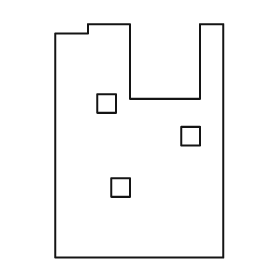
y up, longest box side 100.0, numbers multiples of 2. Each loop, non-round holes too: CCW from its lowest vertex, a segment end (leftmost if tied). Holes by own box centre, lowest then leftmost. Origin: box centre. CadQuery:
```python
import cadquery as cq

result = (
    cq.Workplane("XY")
    .moveTo(-36.0, -50.0)
    .lineTo(36.0, -50.0)
    .lineTo(36.0, 50.0)
    .lineTo(26.0, 50.0)
    .lineTo(26.0, 18.0)
    .lineTo(-4.0, 18.0)
    .lineTo(-4.0, 50.0)
    .lineTo(-22.0, 50.0)
    .lineTo(-22.0, 46.0)
    .lineTo(-36.0, 46.0)
    .close()
    .moveTo(-12.0, -24.0)
    .lineTo(-4.0, -24.0)
    .lineTo(-4.0, -16.0)
    .lineTo(-12.0, -16.0)
    .close()
    .moveTo(18.0, -2.0)
    .lineTo(26.0, -2.0)
    .lineTo(26.0, 6.0)
    .lineTo(18.0, 6.0)
    .close()
    .moveTo(-18.0, 12.0)
    .lineTo(-10.0, 12.0)
    .lineTo(-10.0, 20.0)
    .lineTo(-18.0, 20.0)
    .close()
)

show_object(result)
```